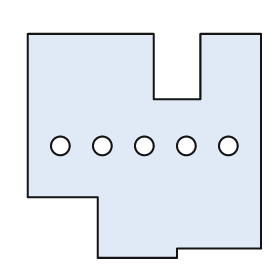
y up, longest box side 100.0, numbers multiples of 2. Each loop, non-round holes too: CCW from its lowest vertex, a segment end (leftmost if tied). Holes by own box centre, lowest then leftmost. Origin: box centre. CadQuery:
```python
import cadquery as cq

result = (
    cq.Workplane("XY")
    .moveTo(-20.0, -48.0)
    .lineTo(14.0, -48.0)
    .lineTo(14.0, -44.0)
    .lineTo(50.0, -44.0)
    .lineTo(50.0, 48.0)
    .lineTo(24.0, 48.0)
    .lineTo(24.0, 20.0)
    .lineTo(4.0, 20.0)
    .lineTo(4.0, 48.0)
    .lineTo(-50.0, 48.0)
    .lineTo(-50.0, -22.0)
    .lineTo(-20.0, -22.0)
    .close()
    .moveTo(-36.0, 0.0)
    .circle(4.0)
    .moveTo(-18.0, 0.0)
    .circle(4.0)
    .moveTo(0.0, 0.0)
    .circle(4.0)
    .moveTo(18.0, 0.0)
    .circle(4.0)
    .moveTo(36.0, 0.0)
    .circle(4.0)
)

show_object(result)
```